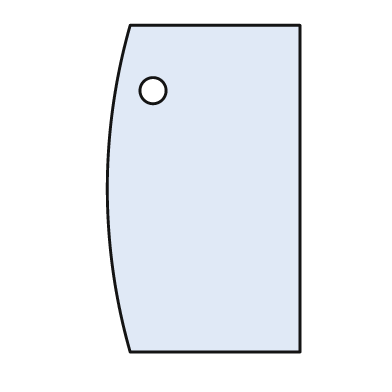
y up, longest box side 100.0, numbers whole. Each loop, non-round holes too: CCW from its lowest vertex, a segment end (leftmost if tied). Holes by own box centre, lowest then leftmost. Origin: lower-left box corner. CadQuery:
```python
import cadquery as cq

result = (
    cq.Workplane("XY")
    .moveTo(7.0, 0.0)
    .lineTo(59.0, 0.0)
    .lineTo(59.0, 100.0)
    .lineTo(7.0, 100.0)
    .threePointArc((0.0, 50.0), (7.0, 0.0))
    .close()
    .moveTo(14.0, 80.0)
    .circle(4.0)
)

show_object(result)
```